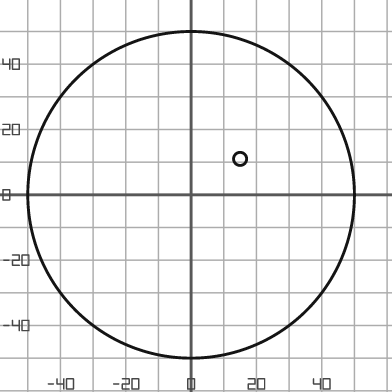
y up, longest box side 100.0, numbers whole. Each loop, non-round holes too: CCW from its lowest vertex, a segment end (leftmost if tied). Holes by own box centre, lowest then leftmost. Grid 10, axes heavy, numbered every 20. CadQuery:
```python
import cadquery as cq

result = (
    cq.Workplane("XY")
    .moveTo(0.0, 0.0)
    .circle(50.0)
    .moveTo(15.0, 11.0)
    .circle(2.0)
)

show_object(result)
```